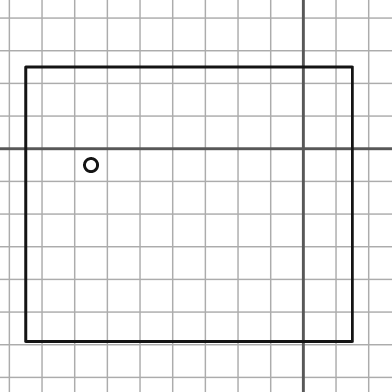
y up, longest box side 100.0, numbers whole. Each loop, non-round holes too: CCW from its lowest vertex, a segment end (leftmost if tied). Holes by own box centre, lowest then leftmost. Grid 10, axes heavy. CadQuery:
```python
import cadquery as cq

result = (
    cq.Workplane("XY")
    .moveTo(-85.0, -59.0)
    .lineTo(15.0, -59.0)
    .lineTo(15.0, 25.0)
    .lineTo(-85.0, 25.0)
    .close()
    .moveTo(-65.0, -5.0)
    .circle(2.0)
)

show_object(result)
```